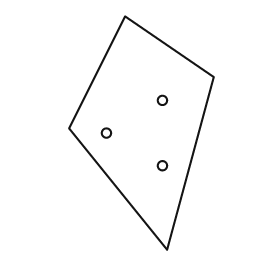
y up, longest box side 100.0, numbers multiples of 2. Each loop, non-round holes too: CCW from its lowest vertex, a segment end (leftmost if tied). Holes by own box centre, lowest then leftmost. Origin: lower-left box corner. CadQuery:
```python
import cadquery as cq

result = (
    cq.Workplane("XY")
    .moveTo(42.0, 0.0)
    .lineTo(62.0, 74.0)
    .lineTo(24.0, 100.0)
    .lineTo(0.0, 52.0)
    .close()
    .moveTo(40.0, 36.0)
    .circle(2.0)
    .moveTo(16.0, 50.0)
    .circle(2.0)
    .moveTo(40.0, 64.0)
    .circle(2.0)
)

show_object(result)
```